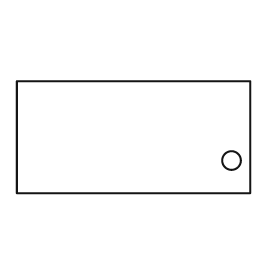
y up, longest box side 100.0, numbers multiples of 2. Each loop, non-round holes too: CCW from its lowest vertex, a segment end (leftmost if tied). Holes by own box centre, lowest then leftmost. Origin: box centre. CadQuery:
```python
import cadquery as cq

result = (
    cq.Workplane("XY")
    .moveTo(-50.0, -24.0)
    .lineTo(50.0, -24.0)
    .lineTo(50.0, 24.0)
    .lineTo(-50.0, 24.0)
    .close()
    .moveTo(42.0, -10.0)
    .circle(4.0)
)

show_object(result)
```